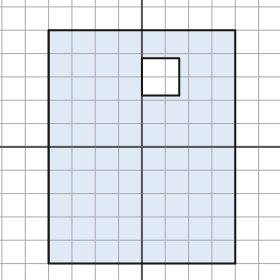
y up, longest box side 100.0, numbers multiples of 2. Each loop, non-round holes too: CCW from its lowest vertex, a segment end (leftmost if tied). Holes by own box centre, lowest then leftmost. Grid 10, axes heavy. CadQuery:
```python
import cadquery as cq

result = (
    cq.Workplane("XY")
    .moveTo(-40.0, -50.0)
    .lineTo(40.0, -50.0)
    .lineTo(40.0, 50.0)
    .lineTo(-40.0, 50.0)
    .close()
    .moveTo(0.0, 22.0)
    .lineTo(16.0, 22.0)
    .lineTo(16.0, 38.0)
    .lineTo(0.0, 38.0)
    .close()
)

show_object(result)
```